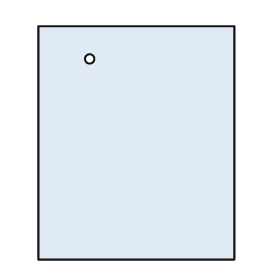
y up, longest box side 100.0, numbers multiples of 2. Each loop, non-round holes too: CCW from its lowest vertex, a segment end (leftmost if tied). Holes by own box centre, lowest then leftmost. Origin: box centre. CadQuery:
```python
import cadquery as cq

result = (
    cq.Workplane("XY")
    .moveTo(-42.0, -50.0)
    .lineTo(42.0, -50.0)
    .lineTo(42.0, 50.0)
    .lineTo(-42.0, 50.0)
    .close()
    .moveTo(-20.0, 36.0)
    .circle(2.0)
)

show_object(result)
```